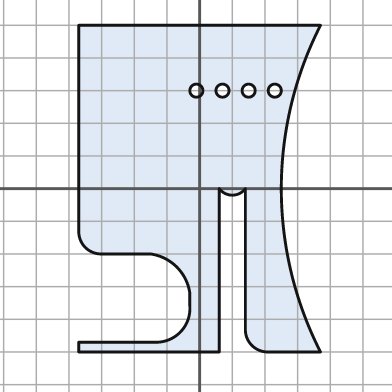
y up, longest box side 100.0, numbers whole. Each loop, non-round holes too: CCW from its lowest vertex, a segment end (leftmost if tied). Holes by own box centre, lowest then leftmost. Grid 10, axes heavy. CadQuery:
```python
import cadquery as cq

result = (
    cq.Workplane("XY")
    .moveTo(-37.0, -50.0)
    .lineTo(6.0, -50.0)
    .lineTo(6.0, 0.0)
    .threePointArc((10.0, -2.0), (14.0, 0.0))
    .lineTo(14.0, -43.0)
    .threePointArc((16.0, -48.0), (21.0, -50.0))
    .lineTo(37.0, -50.0)
    .threePointArc((25.0, 0.0), (37.0, 50.0))
    .lineTo(-37.0, 50.0)
    .lineTo(-37.0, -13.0)
    .threePointArc((-35.0, -18.0), (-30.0, -20.0))
    .lineTo(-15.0, -20.0)
    .threePointArc((-7.0, -24.0), (-3.0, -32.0))
    .lineTo(-3.0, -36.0)
    .threePointArc((-6.0, -44.0), (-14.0, -47.0))
    .lineTo(-37.0, -47.0)
    .close()
    .moveTo(-1.0, 30.0)
    .circle(2.0)
    .moveTo(7.0, 30.0)
    .circle(2.0)
    .moveTo(15.0, 30.0)
    .circle(2.0)
    .moveTo(23.0, 30.0)
    .circle(2.0)
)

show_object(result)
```